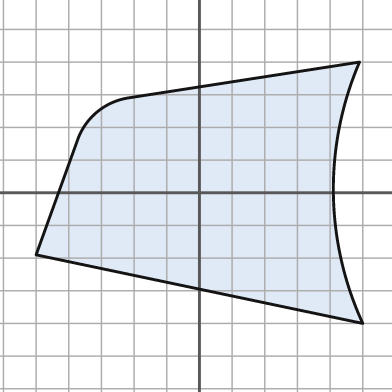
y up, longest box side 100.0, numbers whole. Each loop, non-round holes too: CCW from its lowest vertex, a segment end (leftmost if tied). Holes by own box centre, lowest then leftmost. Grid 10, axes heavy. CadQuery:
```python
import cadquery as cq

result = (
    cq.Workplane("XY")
    .moveTo(50.0, -40.0)
    .threePointArc((41.0, 0.0), (49.0, 40.0))
    .lineTo(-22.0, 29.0)
    .threePointArc((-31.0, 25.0), (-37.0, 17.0))
    .lineTo(-50.0, -19.0)
    .close()
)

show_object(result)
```